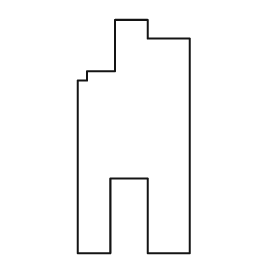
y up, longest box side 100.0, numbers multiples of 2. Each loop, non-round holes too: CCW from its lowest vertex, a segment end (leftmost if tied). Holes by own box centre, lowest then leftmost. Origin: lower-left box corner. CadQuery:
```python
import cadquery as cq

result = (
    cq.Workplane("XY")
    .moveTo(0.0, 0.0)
    .lineTo(14.0, 0.0)
    .lineTo(14.0, 32.0)
    .lineTo(30.0, 32.0)
    .lineTo(30.0, 0.0)
    .lineTo(48.0, 0.0)
    .lineTo(48.0, 92.0)
    .lineTo(30.0, 92.0)
    .lineTo(30.0, 100.0)
    .lineTo(16.0, 100.0)
    .lineTo(16.0, 78.0)
    .lineTo(4.0, 78.0)
    .lineTo(4.0, 74.0)
    .lineTo(0.0, 74.0)
    .close()
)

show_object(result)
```